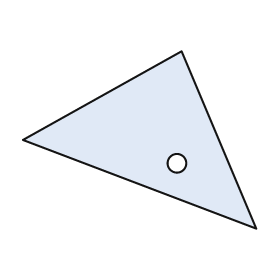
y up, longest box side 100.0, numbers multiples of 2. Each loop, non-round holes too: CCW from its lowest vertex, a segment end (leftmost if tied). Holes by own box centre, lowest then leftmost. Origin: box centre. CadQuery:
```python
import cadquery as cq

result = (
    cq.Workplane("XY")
    .moveTo(50.0, -38.0)
    .lineTo(18.0, 38.0)
    .lineTo(-50.0, 0.0)
    .close()
    .moveTo(16.0, -10.0)
    .circle(4.0)
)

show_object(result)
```